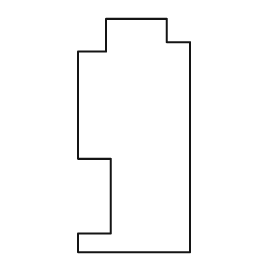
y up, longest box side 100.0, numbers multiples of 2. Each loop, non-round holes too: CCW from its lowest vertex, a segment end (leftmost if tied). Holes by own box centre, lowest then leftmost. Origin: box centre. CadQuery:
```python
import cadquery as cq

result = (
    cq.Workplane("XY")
    .moveTo(-24.0, -50.0)
    .lineTo(24.0, -50.0)
    .lineTo(24.0, 40.0)
    .lineTo(14.0, 40.0)
    .lineTo(14.0, 50.0)
    .lineTo(-12.0, 50.0)
    .lineTo(-12.0, 36.0)
    .lineTo(-24.0, 36.0)
    .lineTo(-24.0, -10.0)
    .lineTo(-10.0, -10.0)
    .lineTo(-10.0, -42.0)
    .lineTo(-24.0, -42.0)
    .close()
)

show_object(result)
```